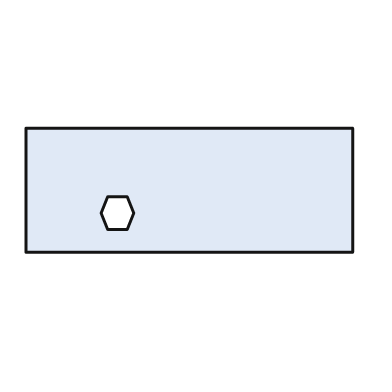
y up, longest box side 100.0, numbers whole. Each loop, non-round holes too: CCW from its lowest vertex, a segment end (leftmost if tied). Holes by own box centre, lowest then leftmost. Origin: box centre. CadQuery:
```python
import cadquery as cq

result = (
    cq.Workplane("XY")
    .moveTo(-50.0, -19.0)
    .lineTo(50.0, -19.0)
    .lineTo(50.0, 19.0)
    .lineTo(-50.0, 19.0)
    .close()
    .moveTo(-25.0, -12.0)
    .lineTo(-19.0, -12.0)
    .lineTo(-17.0, -7.0)
    .lineTo(-19.0, -2.0)
    .lineTo(-25.0, -2.0)
    .lineTo(-27.0, -7.0)
    .close()
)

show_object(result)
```